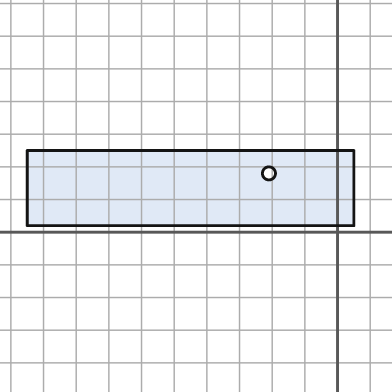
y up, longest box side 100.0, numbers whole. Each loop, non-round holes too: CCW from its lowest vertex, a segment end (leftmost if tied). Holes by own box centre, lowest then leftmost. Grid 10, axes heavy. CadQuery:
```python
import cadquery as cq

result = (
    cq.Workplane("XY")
    .moveTo(-95.0, 2.0)
    .lineTo(5.0, 2.0)
    .lineTo(5.0, 25.0)
    .lineTo(-95.0, 25.0)
    .close()
    .moveTo(-21.0, 18.0)
    .circle(2.0)
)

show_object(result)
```